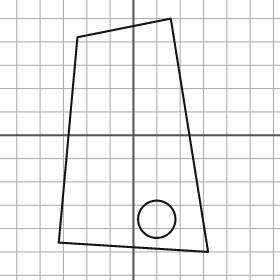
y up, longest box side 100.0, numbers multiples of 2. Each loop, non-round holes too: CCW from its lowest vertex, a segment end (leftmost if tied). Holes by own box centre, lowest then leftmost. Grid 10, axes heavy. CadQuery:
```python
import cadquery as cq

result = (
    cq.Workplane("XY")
    .moveTo(32.0, -50.0)
    .lineTo(16.0, 50.0)
    .lineTo(-24.0, 42.0)
    .lineTo(-32.0, -46.0)
    .close()
    .moveTo(10.0, -36.0)
    .circle(8.0)
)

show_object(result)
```